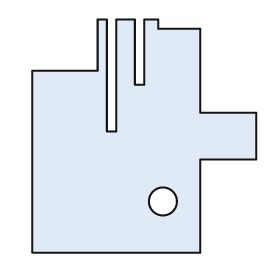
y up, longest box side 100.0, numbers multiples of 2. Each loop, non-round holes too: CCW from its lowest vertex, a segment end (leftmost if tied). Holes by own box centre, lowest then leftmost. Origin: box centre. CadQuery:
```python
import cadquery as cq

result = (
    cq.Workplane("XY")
    .moveTo(-48.0, -50.0)
    .lineTo(24.0, -50.0)
    .lineTo(24.0, -10.0)
    .lineTo(48.0, -10.0)
    .lineTo(48.0, 10.0)
    .lineTo(24.0, 10.0)
    .lineTo(24.0, 46.0)
    .lineTo(6.0, 46.0)
    .lineTo(6.0, 50.0)
    .lineTo(0.0, 50.0)
    .lineTo(0.0, 22.0)
    .lineTo(-4.0, 22.0)
    .lineTo(-4.0, 50.0)
    .lineTo(-12.0, 50.0)
    .lineTo(-12.0, 2.0)
    .lineTo(-16.0, 2.0)
    .lineTo(-16.0, 50.0)
    .lineTo(-20.0, 50.0)
    .lineTo(-20.0, 28.0)
    .lineTo(-48.0, 28.0)
    .close()
    .moveTo(8.0, -28.0)
    .circle(6.0)
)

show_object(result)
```